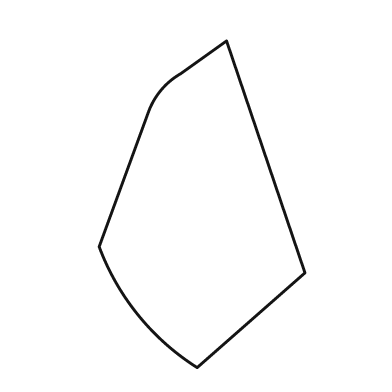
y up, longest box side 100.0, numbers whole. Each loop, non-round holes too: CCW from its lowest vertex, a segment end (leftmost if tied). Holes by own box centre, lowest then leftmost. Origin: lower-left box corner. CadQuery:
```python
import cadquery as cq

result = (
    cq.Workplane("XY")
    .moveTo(30.0, 0.0)
    .lineTo(63.0, 29.0)
    .lineTo(39.0, 100.0)
    .lineTo(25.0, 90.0)
    .threePointArc((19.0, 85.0), (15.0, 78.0))
    .lineTo(0.0, 37.0)
    .threePointArc((12.0, 16.0), (30.0, 0.0))
    .close()
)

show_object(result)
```